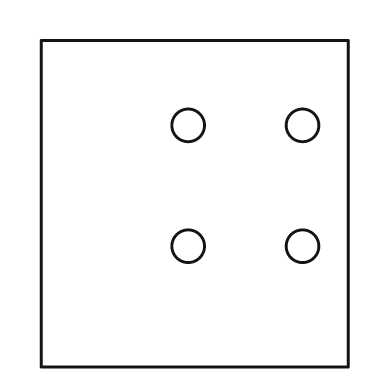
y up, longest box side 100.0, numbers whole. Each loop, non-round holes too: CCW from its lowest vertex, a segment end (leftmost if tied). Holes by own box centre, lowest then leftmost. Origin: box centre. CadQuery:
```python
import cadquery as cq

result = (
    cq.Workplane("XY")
    .moveTo(-47.0, -50.0)
    .lineTo(47.0, -50.0)
    .lineTo(47.0, 50.0)
    .lineTo(-47.0, 50.0)
    .close()
    .moveTo(-2.0, -13.0)
    .circle(5.0)
    .moveTo(33.0, -13.0)
    .circle(5.0)
    .moveTo(-2.0, 24.0)
    .circle(5.0)
    .moveTo(33.0, 24.0)
    .circle(5.0)
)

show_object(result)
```